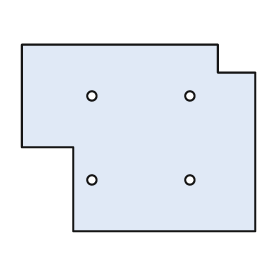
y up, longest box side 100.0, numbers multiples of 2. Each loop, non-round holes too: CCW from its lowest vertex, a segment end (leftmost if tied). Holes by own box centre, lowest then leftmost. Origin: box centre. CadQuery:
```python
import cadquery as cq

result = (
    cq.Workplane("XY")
    .moveTo(-28.0, -40.0)
    .lineTo(50.0, -40.0)
    .lineTo(50.0, 28.0)
    .lineTo(34.0, 28.0)
    .lineTo(34.0, 40.0)
    .lineTo(-50.0, 40.0)
    .lineTo(-50.0, -4.0)
    .lineTo(-28.0, -4.0)
    .close()
    .moveTo(-20.0, -18.0)
    .circle(2.0)
    .moveTo(22.0, -18.0)
    .circle(2.0)
    .moveTo(-20.0, 18.0)
    .circle(2.0)
    .moveTo(22.0, 18.0)
    .circle(2.0)
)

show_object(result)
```